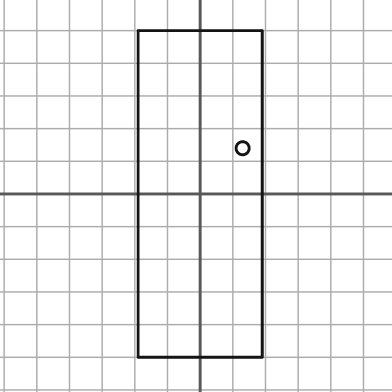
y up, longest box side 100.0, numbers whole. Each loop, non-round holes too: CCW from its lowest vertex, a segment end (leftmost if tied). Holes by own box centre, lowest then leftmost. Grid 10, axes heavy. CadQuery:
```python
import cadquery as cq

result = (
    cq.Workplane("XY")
    .moveTo(-19.0, -50.0)
    .lineTo(19.0, -50.0)
    .lineTo(19.0, 50.0)
    .lineTo(-19.0, 50.0)
    .close()
    .moveTo(13.0, 14.0)
    .circle(2.0)
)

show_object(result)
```